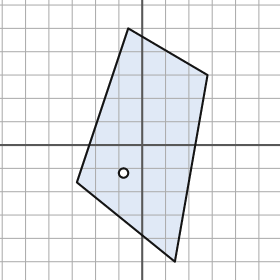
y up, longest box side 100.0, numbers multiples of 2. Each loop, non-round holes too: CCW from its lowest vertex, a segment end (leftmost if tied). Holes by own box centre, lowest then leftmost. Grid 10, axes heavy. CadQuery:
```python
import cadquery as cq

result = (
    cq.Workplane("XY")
    .moveTo(14.0, -50.0)
    .lineTo(28.0, 30.0)
    .lineTo(-6.0, 50.0)
    .lineTo(-28.0, -16.0)
    .close()
    .moveTo(-8.0, -12.0)
    .circle(2.0)
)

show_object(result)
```